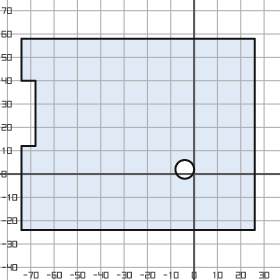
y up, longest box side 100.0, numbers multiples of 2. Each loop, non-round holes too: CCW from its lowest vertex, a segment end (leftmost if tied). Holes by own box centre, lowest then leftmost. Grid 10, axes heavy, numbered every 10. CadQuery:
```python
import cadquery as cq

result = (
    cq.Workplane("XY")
    .moveTo(-74.0, -24.0)
    .lineTo(26.0, -24.0)
    .lineTo(26.0, 58.0)
    .lineTo(-74.0, 58.0)
    .lineTo(-74.0, 40.0)
    .lineTo(-68.0, 40.0)
    .lineTo(-68.0, 12.0)
    .lineTo(-74.0, 12.0)
    .close()
    .moveTo(-4.0, 2.0)
    .circle(4.0)
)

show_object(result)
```